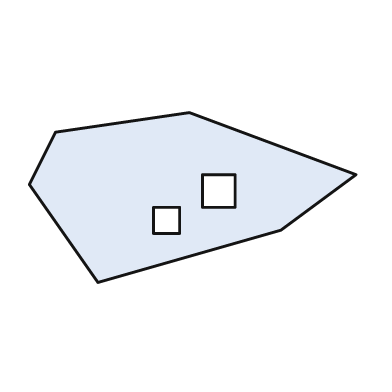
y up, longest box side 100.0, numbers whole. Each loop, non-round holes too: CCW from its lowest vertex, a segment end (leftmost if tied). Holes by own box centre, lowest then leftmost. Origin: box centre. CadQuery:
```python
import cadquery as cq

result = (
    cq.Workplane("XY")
    .moveTo(-29.0, -26.0)
    .lineTo(27.0, -10.0)
    .lineTo(50.0, 7.0)
    .lineTo(-1.0, 26.0)
    .lineTo(-42.0, 20.0)
    .lineTo(-50.0, 4.0)
    .close()
    .moveTo(-12.0, -11.0)
    .lineTo(-4.0, -11.0)
    .lineTo(-4.0, -3.0)
    .lineTo(-12.0, -3.0)
    .close()
    .moveTo(3.0, -3.0)
    .lineTo(13.0, -3.0)
    .lineTo(13.0, 7.0)
    .lineTo(3.0, 7.0)
    .close()
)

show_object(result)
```